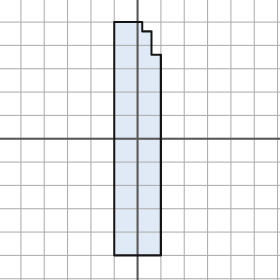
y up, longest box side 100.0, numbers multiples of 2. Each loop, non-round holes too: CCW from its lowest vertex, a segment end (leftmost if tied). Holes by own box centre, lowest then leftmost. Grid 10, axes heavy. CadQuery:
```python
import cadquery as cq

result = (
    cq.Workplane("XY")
    .moveTo(-10.0, -50.0)
    .lineTo(10.0, -50.0)
    .lineTo(10.0, 36.0)
    .lineTo(6.0, 36.0)
    .lineTo(6.0, 46.0)
    .lineTo(2.0, 46.0)
    .lineTo(2.0, 50.0)
    .lineTo(-10.0, 50.0)
    .close()
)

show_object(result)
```